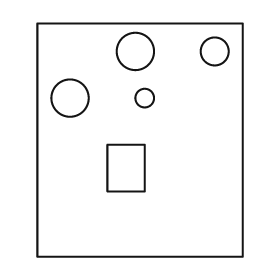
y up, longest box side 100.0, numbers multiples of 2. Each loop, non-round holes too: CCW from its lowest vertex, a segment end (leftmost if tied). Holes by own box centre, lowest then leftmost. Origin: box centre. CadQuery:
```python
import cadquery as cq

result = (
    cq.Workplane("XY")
    .moveTo(-44.0, -50.0)
    .lineTo(44.0, -50.0)
    .lineTo(44.0, 50.0)
    .lineTo(-44.0, 50.0)
    .close()
    .moveTo(-14.0, -22.0)
    .lineTo(2.0, -22.0)
    .lineTo(2.0, -2.0)
    .lineTo(-14.0, -2.0)
    .close()
    .moveTo(-30.0, 18.0)
    .circle(8.0)
    .moveTo(2.0, 18.0)
    .circle(4.0)
    .moveTo(-2.0, 38.0)
    .circle(8.0)
    .moveTo(32.0, 38.0)
    .circle(6.0)
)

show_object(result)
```